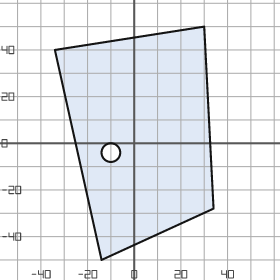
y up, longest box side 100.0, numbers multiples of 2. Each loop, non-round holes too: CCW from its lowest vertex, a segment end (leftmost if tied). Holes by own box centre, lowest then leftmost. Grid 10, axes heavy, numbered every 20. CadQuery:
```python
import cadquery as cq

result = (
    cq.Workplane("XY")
    .moveTo(-14.0, -50.0)
    .lineTo(34.0, -28.0)
    .lineTo(30.0, 50.0)
    .lineTo(-34.0, 40.0)
    .close()
    .moveTo(-10.0, -4.0)
    .circle(4.0)
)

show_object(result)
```